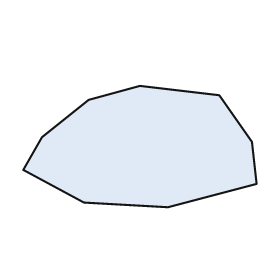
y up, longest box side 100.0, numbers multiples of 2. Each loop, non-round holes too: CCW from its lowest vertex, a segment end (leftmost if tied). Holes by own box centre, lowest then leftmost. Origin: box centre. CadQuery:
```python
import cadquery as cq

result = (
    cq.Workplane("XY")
    .moveTo(12.0, -26.0)
    .lineTo(50.0, -16.0)
    .lineTo(48.0, 2.0)
    .lineTo(34.0, 22.0)
    .lineTo(0.0, 26.0)
    .lineTo(-22.0, 20.0)
    .lineTo(-42.0, 4.0)
    .lineTo(-50.0, -10.0)
    .lineTo(-24.0, -24.0)
    .close()
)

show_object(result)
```